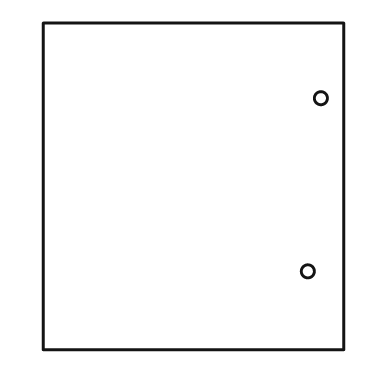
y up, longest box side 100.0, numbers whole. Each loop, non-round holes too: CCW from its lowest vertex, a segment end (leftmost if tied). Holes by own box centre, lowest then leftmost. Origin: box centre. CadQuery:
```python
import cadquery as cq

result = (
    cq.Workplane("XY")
    .moveTo(-46.0, -50.0)
    .lineTo(46.0, -50.0)
    .lineTo(46.0, 50.0)
    .lineTo(-46.0, 50.0)
    .close()
    .moveTo(35.0, -26.0)
    .circle(2.0)
    .moveTo(39.0, 27.0)
    .circle(2.0)
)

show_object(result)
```